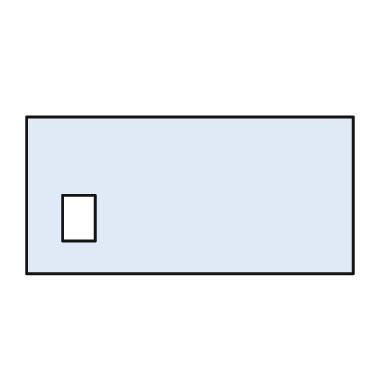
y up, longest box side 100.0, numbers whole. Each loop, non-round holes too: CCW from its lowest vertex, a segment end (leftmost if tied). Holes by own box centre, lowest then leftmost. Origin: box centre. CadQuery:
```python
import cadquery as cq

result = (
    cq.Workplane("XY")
    .moveTo(-50.0, -24.0)
    .lineTo(50.0, -24.0)
    .lineTo(50.0, 24.0)
    .lineTo(-50.0, 24.0)
    .close()
    .moveTo(-39.0, -14.0)
    .lineTo(-29.0, -14.0)
    .lineTo(-29.0, 0.0)
    .lineTo(-39.0, 0.0)
    .close()
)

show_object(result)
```